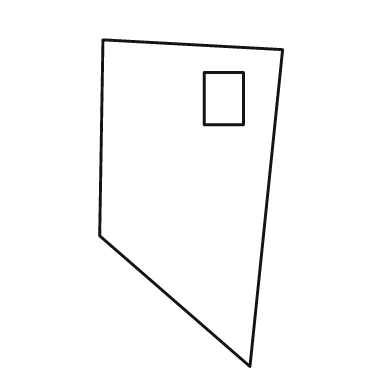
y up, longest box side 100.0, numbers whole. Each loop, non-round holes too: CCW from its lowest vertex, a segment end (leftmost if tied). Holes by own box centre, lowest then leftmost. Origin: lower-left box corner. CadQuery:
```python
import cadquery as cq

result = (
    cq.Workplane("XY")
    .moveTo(46.0, 0.0)
    .lineTo(56.0, 97.0)
    .lineTo(1.0, 100.0)
    .lineTo(0.0, 40.0)
    .close()
    .moveTo(32.0, 74.0)
    .lineTo(44.0, 74.0)
    .lineTo(44.0, 90.0)
    .lineTo(32.0, 90.0)
    .close()
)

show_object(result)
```